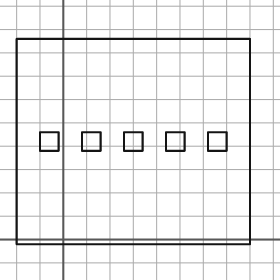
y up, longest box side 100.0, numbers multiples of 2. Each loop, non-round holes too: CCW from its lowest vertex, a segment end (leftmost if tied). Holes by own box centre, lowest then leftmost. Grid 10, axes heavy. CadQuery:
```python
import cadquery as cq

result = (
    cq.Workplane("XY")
    .moveTo(-20.0, -2.0)
    .lineTo(80.0, -2.0)
    .lineTo(80.0, 86.0)
    .lineTo(-20.0, 86.0)
    .close()
    .moveTo(-10.0, 38.0)
    .lineTo(-2.0, 38.0)
    .lineTo(-2.0, 46.0)
    .lineTo(-10.0, 46.0)
    .close()
    .moveTo(8.0, 38.0)
    .lineTo(16.0, 38.0)
    .lineTo(16.0, 46.0)
    .lineTo(8.0, 46.0)
    .close()
    .moveTo(26.0, 38.0)
    .lineTo(34.0, 38.0)
    .lineTo(34.0, 46.0)
    .lineTo(26.0, 46.0)
    .close()
    .moveTo(44.0, 38.0)
    .lineTo(52.0, 38.0)
    .lineTo(52.0, 46.0)
    .lineTo(44.0, 46.0)
    .close()
    .moveTo(62.0, 38.0)
    .lineTo(70.0, 38.0)
    .lineTo(70.0, 46.0)
    .lineTo(62.0, 46.0)
    .close()
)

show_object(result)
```